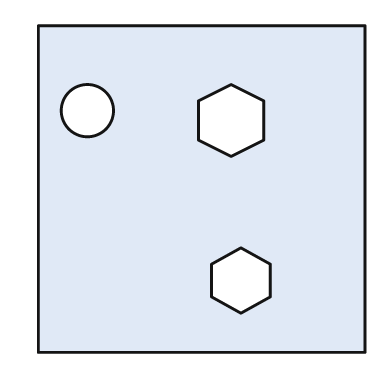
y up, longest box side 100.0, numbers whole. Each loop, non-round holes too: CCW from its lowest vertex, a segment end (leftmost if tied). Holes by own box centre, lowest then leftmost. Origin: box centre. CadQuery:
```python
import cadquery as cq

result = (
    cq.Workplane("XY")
    .moveTo(-50.0, -50.0)
    .lineTo(50.0, -50.0)
    .lineTo(50.0, 50.0)
    .lineTo(-50.0, 50.0)
    .close()
    .moveTo(12.0, -38.0)
    .lineTo(21.0, -33.0)
    .lineTo(21.0, -23.0)
    .lineTo(12.0, -18.0)
    .lineTo(3.0, -23.0)
    .lineTo(3.0, -33.0)
    .close()
    .moveTo(9.0, 10.0)
    .lineTo(19.0, 15.0)
    .lineTo(19.0, 27.0)
    .lineTo(9.0, 32.0)
    .lineTo(-1.0, 27.0)
    .lineTo(-1.0, 15.0)
    .close()
    .moveTo(-35.0, 24.0)
    .circle(8.0)
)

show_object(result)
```